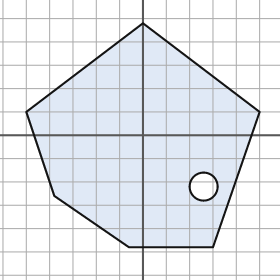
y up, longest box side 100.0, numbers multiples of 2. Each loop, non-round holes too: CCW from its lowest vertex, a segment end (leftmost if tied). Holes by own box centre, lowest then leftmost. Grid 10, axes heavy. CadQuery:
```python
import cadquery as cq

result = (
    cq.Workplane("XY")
    .moveTo(-6.0, -48.0)
    .lineTo(30.0, -48.0)
    .lineTo(50.0, 10.0)
    .lineTo(0.0, 48.0)
    .lineTo(-50.0, 10.0)
    .lineTo(-38.0, -26.0)
    .close()
    .moveTo(26.0, -22.0)
    .circle(6.0)
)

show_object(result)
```